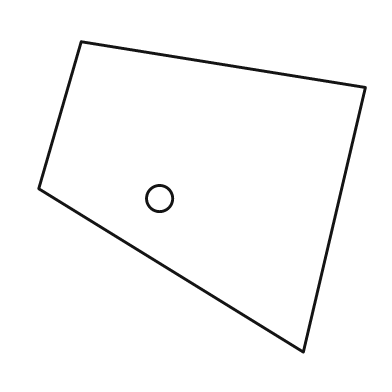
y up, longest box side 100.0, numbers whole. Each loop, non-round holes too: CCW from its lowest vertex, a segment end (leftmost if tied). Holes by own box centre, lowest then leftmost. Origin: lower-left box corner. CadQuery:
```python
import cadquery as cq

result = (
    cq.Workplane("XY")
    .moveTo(81.0, 0.0)
    .lineTo(100.0, 81.0)
    .lineTo(13.0, 95.0)
    .lineTo(0.0, 50.0)
    .close()
    .moveTo(37.0, 47.0)
    .circle(4.0)
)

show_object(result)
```